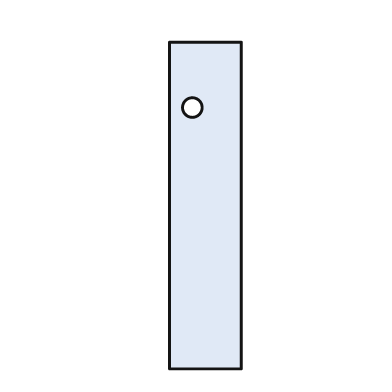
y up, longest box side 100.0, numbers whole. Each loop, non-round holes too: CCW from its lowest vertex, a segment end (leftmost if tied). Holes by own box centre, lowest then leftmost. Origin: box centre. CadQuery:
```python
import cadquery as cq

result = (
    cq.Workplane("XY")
    .moveTo(-11.0, -50.0)
    .lineTo(11.0, -50.0)
    .lineTo(11.0, 50.0)
    .lineTo(-11.0, 50.0)
    .close()
    .moveTo(-4.0, 30.0)
    .circle(3.0)
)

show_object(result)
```